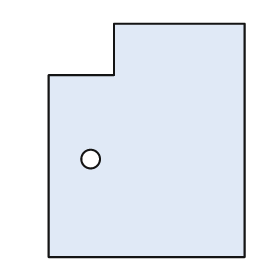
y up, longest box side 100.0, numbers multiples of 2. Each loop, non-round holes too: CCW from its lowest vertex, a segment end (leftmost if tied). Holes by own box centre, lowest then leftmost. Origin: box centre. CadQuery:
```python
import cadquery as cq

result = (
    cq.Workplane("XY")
    .moveTo(-42.0, -50.0)
    .lineTo(42.0, -50.0)
    .lineTo(42.0, 50.0)
    .lineTo(-14.0, 50.0)
    .lineTo(-14.0, 28.0)
    .lineTo(-42.0, 28.0)
    .close()
    .moveTo(-24.0, -8.0)
    .circle(4.0)
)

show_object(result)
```